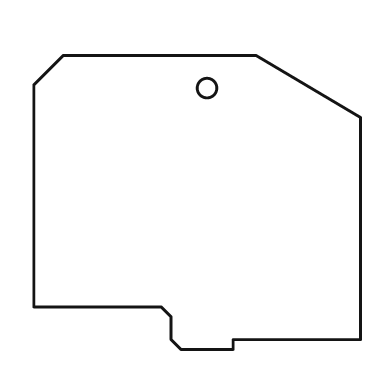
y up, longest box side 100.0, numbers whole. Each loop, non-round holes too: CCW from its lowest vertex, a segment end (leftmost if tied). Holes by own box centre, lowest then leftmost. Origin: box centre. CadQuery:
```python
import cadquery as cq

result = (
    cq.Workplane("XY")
    .moveTo(-5.0, -45.0)
    .lineTo(11.0, -45.0)
    .lineTo(11.0, -42.0)
    .lineTo(50.0, -42.0)
    .lineTo(50.0, 26.0)
    .lineTo(18.0, 45.0)
    .lineTo(-41.0, 45.0)
    .lineTo(-50.0, 36.0)
    .lineTo(-50.0, -32.0)
    .lineTo(-11.0, -32.0)
    .lineTo(-8.0, -35.0)
    .lineTo(-8.0, -42.0)
    .close()
    .moveTo(3.0, 35.0)
    .circle(3.0)
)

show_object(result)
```